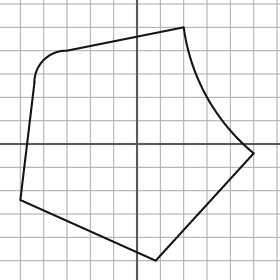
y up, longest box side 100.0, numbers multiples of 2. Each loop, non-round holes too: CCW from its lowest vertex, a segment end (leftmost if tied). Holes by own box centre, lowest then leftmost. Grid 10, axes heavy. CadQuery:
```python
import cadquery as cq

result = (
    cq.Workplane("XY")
    .moveTo(8.0, -50.0)
    .lineTo(50.0, -4.0)
    .threePointArc((30.0, 20.0), (20.0, 50.0))
    .lineTo(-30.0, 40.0)
    .threePointArc((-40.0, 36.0), (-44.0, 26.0))
    .lineTo(-50.0, -24.0)
    .close()
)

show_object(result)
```